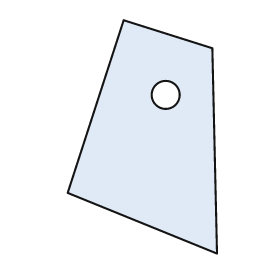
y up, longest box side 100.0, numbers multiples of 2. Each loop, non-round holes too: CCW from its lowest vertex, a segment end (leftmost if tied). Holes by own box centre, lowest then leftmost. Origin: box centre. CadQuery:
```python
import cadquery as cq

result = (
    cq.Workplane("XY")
    .moveTo(32.0, -50.0)
    .lineTo(30.0, 38.0)
    .lineTo(-8.0, 50.0)
    .lineTo(-32.0, -24.0)
    .close()
    .moveTo(10.0, 18.0)
    .circle(6.0)
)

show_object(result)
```